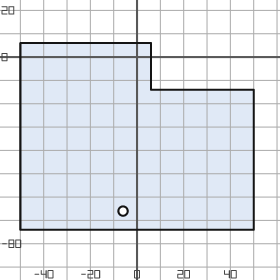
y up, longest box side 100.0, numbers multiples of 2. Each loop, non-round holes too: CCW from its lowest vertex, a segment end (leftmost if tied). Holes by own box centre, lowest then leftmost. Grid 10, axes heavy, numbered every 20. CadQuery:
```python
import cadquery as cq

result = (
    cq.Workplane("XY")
    .moveTo(-50.0, -74.0)
    .lineTo(50.0, -74.0)
    .lineTo(50.0, -14.0)
    .lineTo(6.0, -14.0)
    .lineTo(6.0, 6.0)
    .lineTo(-50.0, 6.0)
    .close()
    .moveTo(-6.0, -66.0)
    .circle(2.0)
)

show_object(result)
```